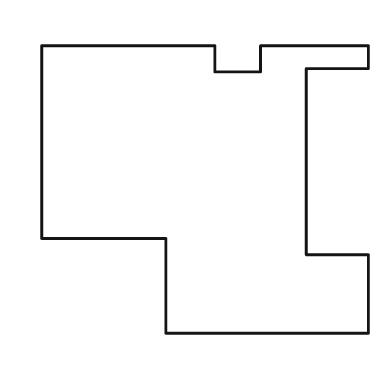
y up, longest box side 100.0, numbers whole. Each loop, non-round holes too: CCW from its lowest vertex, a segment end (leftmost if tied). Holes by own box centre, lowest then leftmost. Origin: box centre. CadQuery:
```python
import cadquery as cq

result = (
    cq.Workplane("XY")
    .moveTo(-12.0, -44.0)
    .lineTo(50.0, -44.0)
    .lineTo(50.0, -20.0)
    .lineTo(31.0, -20.0)
    .lineTo(31.0, 37.0)
    .lineTo(50.0, 37.0)
    .lineTo(50.0, 44.0)
    .lineTo(17.0, 44.0)
    .lineTo(17.0, 36.0)
    .lineTo(3.0, 36.0)
    .lineTo(3.0, 44.0)
    .lineTo(-50.0, 44.0)
    .lineTo(-50.0, -15.0)
    .lineTo(-12.0, -15.0)
    .close()
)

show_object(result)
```